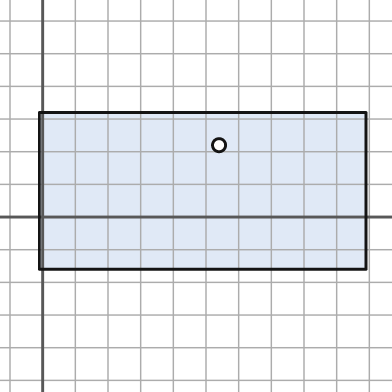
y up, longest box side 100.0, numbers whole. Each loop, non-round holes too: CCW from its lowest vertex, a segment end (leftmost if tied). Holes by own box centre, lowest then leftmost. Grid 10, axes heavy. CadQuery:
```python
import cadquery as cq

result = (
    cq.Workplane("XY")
    .moveTo(-1.0, -16.0)
    .lineTo(99.0, -16.0)
    .lineTo(99.0, 32.0)
    .lineTo(-1.0, 32.0)
    .close()
    .moveTo(54.0, 22.0)
    .circle(2.0)
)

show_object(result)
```